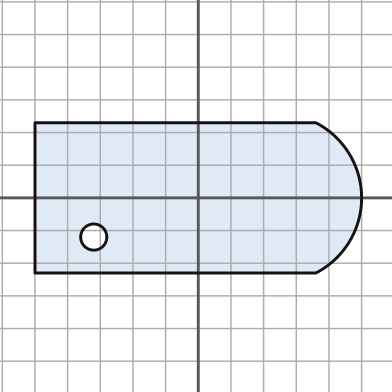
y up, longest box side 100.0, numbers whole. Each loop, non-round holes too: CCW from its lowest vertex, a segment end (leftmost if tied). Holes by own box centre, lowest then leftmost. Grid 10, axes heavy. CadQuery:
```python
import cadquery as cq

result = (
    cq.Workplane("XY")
    .moveTo(-50.0, -23.0)
    .lineTo(36.0, -23.0)
    .threePointArc((50.0, 0.0), (36.0, 23.0))
    .lineTo(-50.0, 23.0)
    .close()
    .moveTo(-32.0, -12.0)
    .circle(4.0)
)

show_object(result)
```